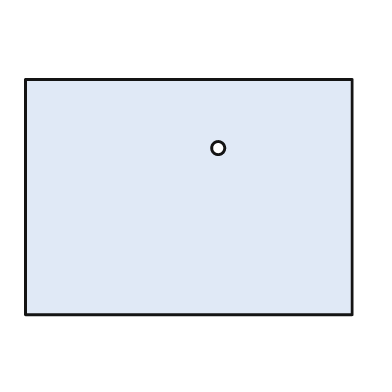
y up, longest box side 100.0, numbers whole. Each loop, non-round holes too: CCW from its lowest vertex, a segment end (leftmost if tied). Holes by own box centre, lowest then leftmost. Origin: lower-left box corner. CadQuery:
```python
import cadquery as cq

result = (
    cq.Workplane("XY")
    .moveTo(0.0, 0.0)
    .lineTo(100.0, 0.0)
    .lineTo(100.0, 72.0)
    .lineTo(0.0, 72.0)
    .close()
    .moveTo(59.0, 51.0)
    .circle(2.0)
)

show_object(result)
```